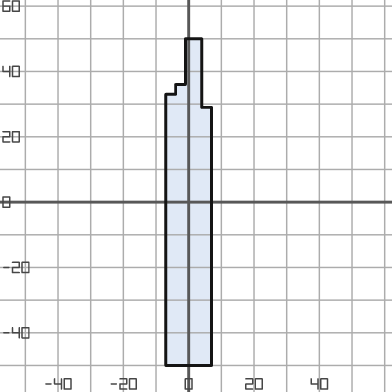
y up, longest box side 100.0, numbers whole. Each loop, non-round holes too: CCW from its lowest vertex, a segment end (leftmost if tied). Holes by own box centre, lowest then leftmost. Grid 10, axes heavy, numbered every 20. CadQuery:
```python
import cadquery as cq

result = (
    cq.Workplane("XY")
    .moveTo(-7.0, -50.0)
    .lineTo(7.0, -50.0)
    .lineTo(7.0, 29.0)
    .lineTo(4.0, 29.0)
    .lineTo(4.0, 50.0)
    .lineTo(-1.0, 50.0)
    .lineTo(-1.0, 36.0)
    .lineTo(-4.0, 36.0)
    .lineTo(-4.0, 33.0)
    .lineTo(-7.0, 33.0)
    .close()
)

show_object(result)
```